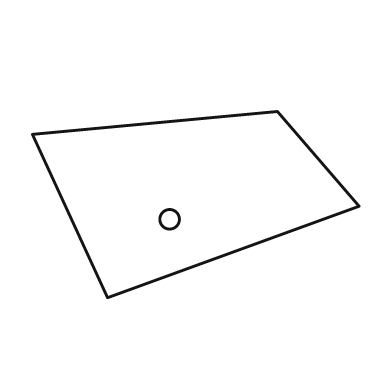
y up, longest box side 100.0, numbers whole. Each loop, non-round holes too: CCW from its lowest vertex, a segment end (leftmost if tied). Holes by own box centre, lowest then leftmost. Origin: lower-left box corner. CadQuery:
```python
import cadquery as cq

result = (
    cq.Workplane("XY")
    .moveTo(23.0, 0.0)
    .lineTo(100.0, 28.0)
    .lineTo(75.0, 57.0)
    .lineTo(0.0, 50.0)
    .close()
    .moveTo(42.0, 24.0)
    .circle(3.0)
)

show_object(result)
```